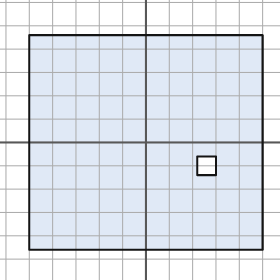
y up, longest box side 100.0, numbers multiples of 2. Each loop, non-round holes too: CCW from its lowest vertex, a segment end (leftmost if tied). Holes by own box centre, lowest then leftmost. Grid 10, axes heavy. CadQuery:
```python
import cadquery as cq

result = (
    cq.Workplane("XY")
    .moveTo(-50.0, -46.0)
    .lineTo(50.0, -46.0)
    .lineTo(50.0, 46.0)
    .lineTo(-50.0, 46.0)
    .close()
    .moveTo(22.0, -14.0)
    .lineTo(30.0, -14.0)
    .lineTo(30.0, -6.0)
    .lineTo(22.0, -6.0)
    .close()
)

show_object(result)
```